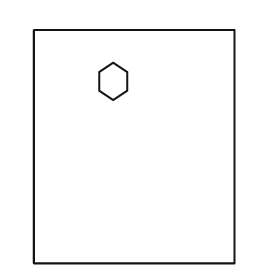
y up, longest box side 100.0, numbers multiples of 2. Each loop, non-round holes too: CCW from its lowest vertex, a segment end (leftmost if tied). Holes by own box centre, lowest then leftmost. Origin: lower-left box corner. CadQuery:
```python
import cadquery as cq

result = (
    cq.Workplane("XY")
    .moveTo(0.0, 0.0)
    .lineTo(86.0, 0.0)
    .lineTo(86.0, 100.0)
    .lineTo(0.0, 100.0)
    .close()
    .moveTo(34.0, 70.0)
    .lineTo(40.0, 74.0)
    .lineTo(40.0, 82.0)
    .lineTo(34.0, 86.0)
    .lineTo(28.0, 82.0)
    .lineTo(28.0, 74.0)
    .close()
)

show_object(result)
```